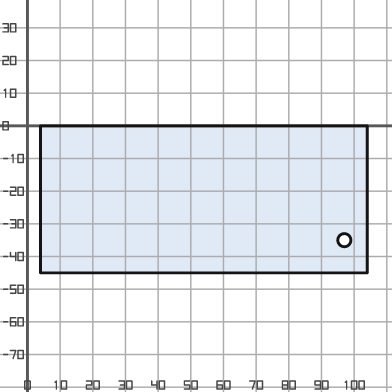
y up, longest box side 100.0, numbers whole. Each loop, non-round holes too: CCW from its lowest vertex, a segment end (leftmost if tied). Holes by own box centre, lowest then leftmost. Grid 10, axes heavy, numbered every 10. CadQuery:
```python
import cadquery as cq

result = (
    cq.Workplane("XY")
    .moveTo(4.0, -45.0)
    .lineTo(104.0, -45.0)
    .lineTo(104.0, 0.0)
    .lineTo(4.0, 0.0)
    .close()
    .moveTo(97.0, -35.0)
    .circle(2.0)
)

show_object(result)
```